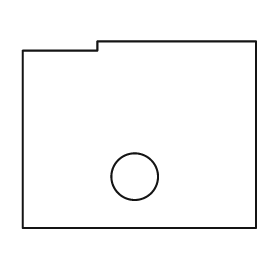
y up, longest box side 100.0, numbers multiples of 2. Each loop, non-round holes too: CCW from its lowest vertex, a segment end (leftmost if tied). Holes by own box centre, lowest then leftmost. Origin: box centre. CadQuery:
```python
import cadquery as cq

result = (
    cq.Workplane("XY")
    .moveTo(-50.0, -40.0)
    .lineTo(50.0, -40.0)
    .lineTo(50.0, 40.0)
    .lineTo(-18.0, 40.0)
    .lineTo(-18.0, 36.0)
    .lineTo(-50.0, 36.0)
    .close()
    .moveTo(-2.0, -18.0)
    .circle(10.0)
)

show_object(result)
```